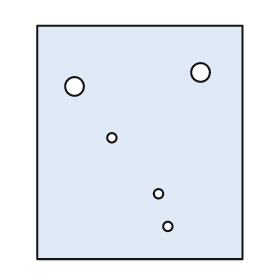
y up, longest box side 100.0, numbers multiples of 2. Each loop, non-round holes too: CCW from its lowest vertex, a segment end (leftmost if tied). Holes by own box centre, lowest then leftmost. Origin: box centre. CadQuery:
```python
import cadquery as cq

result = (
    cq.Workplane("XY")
    .moveTo(-44.0, -50.0)
    .lineTo(44.0, -50.0)
    .lineTo(44.0, 50.0)
    .lineTo(-44.0, 50.0)
    .close()
    .moveTo(12.0, -36.0)
    .circle(2.0)
    .moveTo(8.0, -22.0)
    .circle(2.0)
    .moveTo(-12.0, 2.0)
    .circle(2.0)
    .moveTo(-28.0, 24.0)
    .circle(4.0)
    .moveTo(26.0, 30.0)
    .circle(4.0)
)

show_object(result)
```